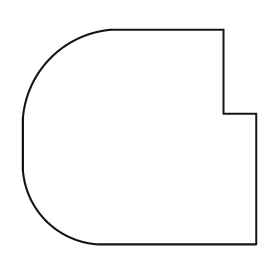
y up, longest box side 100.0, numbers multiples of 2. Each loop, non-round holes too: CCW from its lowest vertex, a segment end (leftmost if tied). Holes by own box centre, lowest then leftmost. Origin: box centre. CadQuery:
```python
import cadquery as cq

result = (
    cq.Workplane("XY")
    .moveTo(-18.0, -46.0)
    .lineTo(50.0, -46.0)
    .lineTo(50.0, 10.0)
    .lineTo(36.0, 10.0)
    .lineTo(36.0, 46.0)
    .lineTo(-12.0, 46.0)
    .threePointArc((-38.0, 34.0), (-50.0, 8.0))
    .lineTo(-50.0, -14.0)
    .threePointArc((-40.0, -36.0), (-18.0, -46.0))
    .close()
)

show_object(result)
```